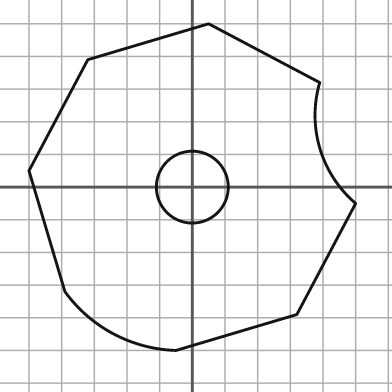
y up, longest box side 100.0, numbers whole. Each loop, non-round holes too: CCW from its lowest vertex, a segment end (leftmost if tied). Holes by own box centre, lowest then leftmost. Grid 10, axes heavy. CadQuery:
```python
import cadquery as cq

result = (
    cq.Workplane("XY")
    .moveTo(-5.0, -50.0)
    .lineTo(32.0, -39.0)
    .lineTo(50.0, -5.0)
    .threePointArc((39.0, 12.0), (39.0, 32.0))
    .lineTo(5.0, 50.0)
    .lineTo(-32.0, 39.0)
    .lineTo(-50.0, 5.0)
    .lineTo(-39.0, -32.0)
    .threePointArc((-24.0, -45.0), (-5.0, -50.0))
    .close()
    .moveTo(0.0, 0.0)
    .circle(11.0)
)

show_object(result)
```